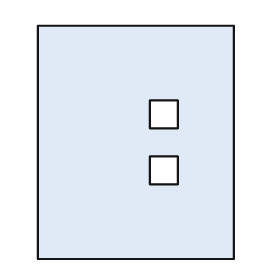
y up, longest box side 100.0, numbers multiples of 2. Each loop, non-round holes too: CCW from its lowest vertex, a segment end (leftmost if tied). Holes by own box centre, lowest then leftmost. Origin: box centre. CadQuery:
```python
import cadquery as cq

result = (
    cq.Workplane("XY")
    .moveTo(-42.0, -50.0)
    .lineTo(42.0, -50.0)
    .lineTo(42.0, 50.0)
    .lineTo(-42.0, 50.0)
    .close()
    .moveTo(6.0, -18.0)
    .lineTo(18.0, -18.0)
    .lineTo(18.0, -6.0)
    .lineTo(6.0, -6.0)
    .close()
    .moveTo(6.0, 6.0)
    .lineTo(18.0, 6.0)
    .lineTo(18.0, 18.0)
    .lineTo(6.0, 18.0)
    .close()
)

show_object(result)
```